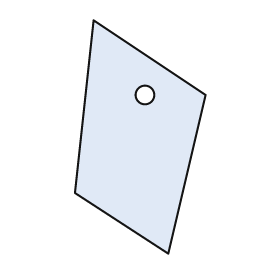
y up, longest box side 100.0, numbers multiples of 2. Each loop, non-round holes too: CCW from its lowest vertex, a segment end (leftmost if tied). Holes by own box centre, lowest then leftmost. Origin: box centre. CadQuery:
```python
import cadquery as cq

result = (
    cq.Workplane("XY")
    .moveTo(12.0, -50.0)
    .lineTo(28.0, 18.0)
    .lineTo(-20.0, 50.0)
    .lineTo(-28.0, -24.0)
    .close()
    .moveTo(2.0, 18.0)
    .circle(4.0)
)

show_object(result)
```